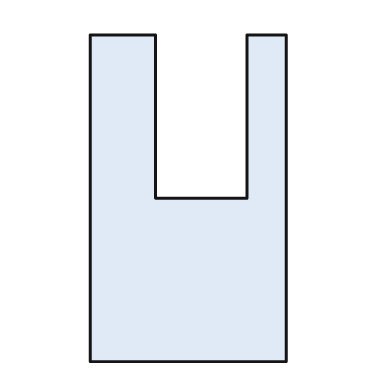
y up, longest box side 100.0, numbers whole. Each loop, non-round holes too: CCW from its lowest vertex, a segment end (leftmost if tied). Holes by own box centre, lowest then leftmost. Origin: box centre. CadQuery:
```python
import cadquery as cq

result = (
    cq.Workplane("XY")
    .moveTo(-30.0, -50.0)
    .lineTo(30.0, -50.0)
    .lineTo(30.0, 50.0)
    .lineTo(18.0, 50.0)
    .lineTo(18.0, 0.0)
    .lineTo(-10.0, 0.0)
    .lineTo(-10.0, 50.0)
    .lineTo(-30.0, 50.0)
    .close()
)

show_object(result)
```